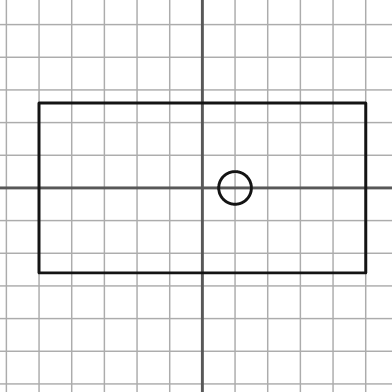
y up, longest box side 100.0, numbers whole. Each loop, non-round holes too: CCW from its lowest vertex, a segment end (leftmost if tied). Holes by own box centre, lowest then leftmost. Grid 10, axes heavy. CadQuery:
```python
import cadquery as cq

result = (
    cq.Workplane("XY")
    .moveTo(-50.0, -26.0)
    .lineTo(50.0, -26.0)
    .lineTo(50.0, 26.0)
    .lineTo(-50.0, 26.0)
    .close()
    .moveTo(10.0, 0.0)
    .circle(5.0)
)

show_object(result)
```